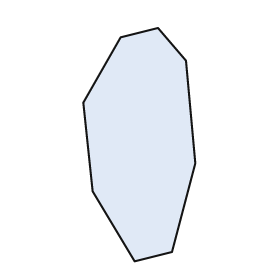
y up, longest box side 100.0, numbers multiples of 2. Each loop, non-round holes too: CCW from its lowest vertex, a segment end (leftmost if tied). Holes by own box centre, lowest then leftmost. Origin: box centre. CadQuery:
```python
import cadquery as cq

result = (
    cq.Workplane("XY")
    .moveTo(-2.0, -50.0)
    .lineTo(14.0, -46.0)
    .lineTo(24.0, -8.0)
    .lineTo(20.0, 36.0)
    .lineTo(8.0, 50.0)
    .lineTo(-8.0, 46.0)
    .lineTo(-24.0, 18.0)
    .lineTo(-20.0, -20.0)
    .close()
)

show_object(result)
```